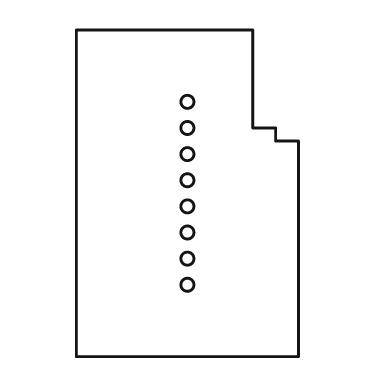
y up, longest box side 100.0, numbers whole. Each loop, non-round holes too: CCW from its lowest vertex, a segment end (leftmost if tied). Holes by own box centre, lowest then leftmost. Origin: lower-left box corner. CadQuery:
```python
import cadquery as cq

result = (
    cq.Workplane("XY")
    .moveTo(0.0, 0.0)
    .lineTo(68.0, 0.0)
    .lineTo(68.0, 66.0)
    .lineTo(61.0, 66.0)
    .lineTo(61.0, 70.0)
    .lineTo(54.0, 70.0)
    .lineTo(54.0, 100.0)
    .lineTo(0.0, 100.0)
    .close()
    .moveTo(34.0, 22.0)
    .circle(2.0)
    .moveTo(34.0, 30.0)
    .circle(2.0)
    .moveTo(34.0, 38.0)
    .circle(2.0)
    .moveTo(34.0, 46.0)
    .circle(2.0)
    .moveTo(34.0, 54.0)
    .circle(2.0)
    .moveTo(34.0, 62.0)
    .circle(2.0)
    .moveTo(34.0, 70.0)
    .circle(2.0)
    .moveTo(34.0, 78.0)
    .circle(2.0)
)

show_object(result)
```